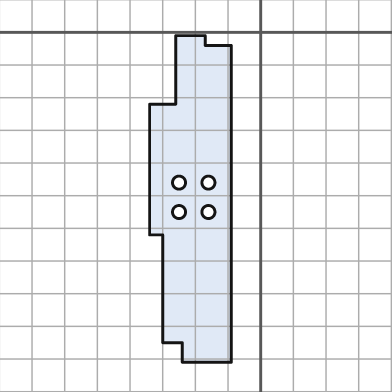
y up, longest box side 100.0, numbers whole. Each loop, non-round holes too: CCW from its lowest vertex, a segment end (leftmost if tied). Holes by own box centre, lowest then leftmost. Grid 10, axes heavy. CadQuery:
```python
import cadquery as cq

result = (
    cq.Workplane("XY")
    .moveTo(-24.0, -101.0)
    .lineTo(-9.0, -101.0)
    .lineTo(-9.0, -4.0)
    .lineTo(-17.0, -4.0)
    .lineTo(-17.0, -1.0)
    .lineTo(-26.0, -1.0)
    .lineTo(-26.0, -22.0)
    .lineTo(-34.0, -22.0)
    .lineTo(-34.0, -62.0)
    .lineTo(-30.0, -62.0)
    .lineTo(-30.0, -95.0)
    .lineTo(-24.0, -95.0)
    .close()
    .moveTo(-25.0, -55.0)
    .circle(2.0)
    .moveTo(-16.0, -55.0)
    .circle(2.0)
    .moveTo(-25.0, -46.0)
    .circle(2.0)
    .moveTo(-16.0, -46.0)
    .circle(2.0)
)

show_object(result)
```